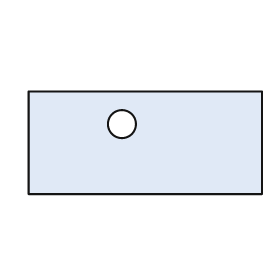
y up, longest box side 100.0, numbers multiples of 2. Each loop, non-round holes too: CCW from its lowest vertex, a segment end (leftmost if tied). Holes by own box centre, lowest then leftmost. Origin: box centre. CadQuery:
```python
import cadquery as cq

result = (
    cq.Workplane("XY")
    .moveTo(-50.0, -22.0)
    .lineTo(50.0, -22.0)
    .lineTo(50.0, 22.0)
    .lineTo(-50.0, 22.0)
    .close()
    .moveTo(-10.0, 8.0)
    .circle(6.0)
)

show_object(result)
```